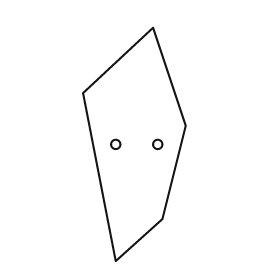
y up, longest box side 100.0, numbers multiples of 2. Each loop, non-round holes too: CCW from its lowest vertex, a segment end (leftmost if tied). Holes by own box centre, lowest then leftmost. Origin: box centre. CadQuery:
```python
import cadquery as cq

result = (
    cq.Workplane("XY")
    .moveTo(-8.0, -50.0)
    .lineTo(12.0, -32.0)
    .lineTo(22.0, 8.0)
    .lineTo(8.0, 50.0)
    .lineTo(-22.0, 22.0)
    .close()
    .moveTo(-8.0, 0.0)
    .circle(2.0)
    .moveTo(10.0, 0.0)
    .circle(2.0)
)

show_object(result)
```